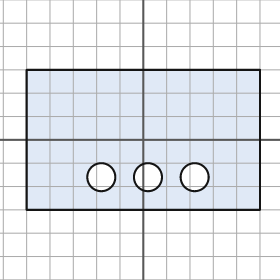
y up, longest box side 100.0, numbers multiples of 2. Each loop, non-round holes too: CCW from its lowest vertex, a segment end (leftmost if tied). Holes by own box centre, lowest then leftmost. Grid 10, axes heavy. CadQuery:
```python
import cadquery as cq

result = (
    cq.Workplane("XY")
    .moveTo(-50.0, -30.0)
    .lineTo(50.0, -30.0)
    .lineTo(50.0, 30.0)
    .lineTo(-50.0, 30.0)
    .close()
    .moveTo(-18.0, -16.0)
    .circle(6.0)
    .moveTo(2.0, -16.0)
    .circle(6.0)
    .moveTo(22.0, -16.0)
    .circle(6.0)
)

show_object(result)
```